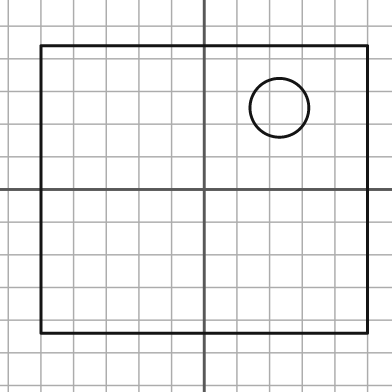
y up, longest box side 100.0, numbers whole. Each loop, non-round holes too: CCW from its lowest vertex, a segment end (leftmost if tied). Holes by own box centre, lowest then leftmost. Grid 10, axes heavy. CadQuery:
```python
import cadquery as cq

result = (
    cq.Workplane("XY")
    .moveTo(-50.0, -44.0)
    .lineTo(50.0, -44.0)
    .lineTo(50.0, 44.0)
    .lineTo(-50.0, 44.0)
    .close()
    .moveTo(23.0, 25.0)
    .circle(9.0)
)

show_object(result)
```